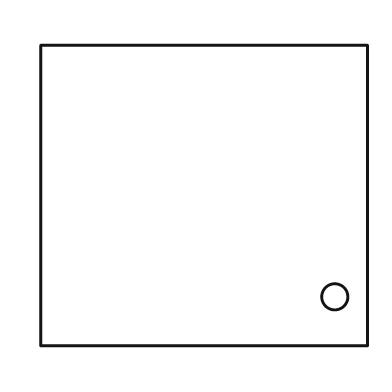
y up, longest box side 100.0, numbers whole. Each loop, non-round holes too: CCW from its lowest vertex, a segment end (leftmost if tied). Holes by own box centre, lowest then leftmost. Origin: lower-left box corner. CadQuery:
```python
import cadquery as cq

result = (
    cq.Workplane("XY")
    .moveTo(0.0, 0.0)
    .lineTo(100.0, 0.0)
    .lineTo(100.0, 92.0)
    .lineTo(0.0, 92.0)
    .close()
    .moveTo(90.0, 15.0)
    .circle(4.0)
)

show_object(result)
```